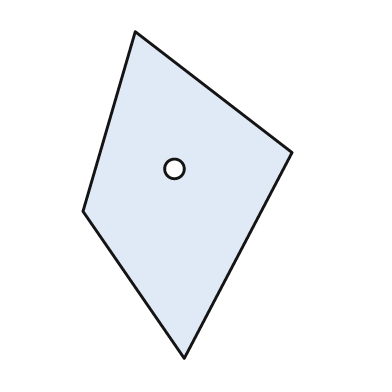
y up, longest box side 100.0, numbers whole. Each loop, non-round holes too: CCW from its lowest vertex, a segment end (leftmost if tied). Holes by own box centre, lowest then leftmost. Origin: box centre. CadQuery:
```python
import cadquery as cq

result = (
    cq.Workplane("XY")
    .moveTo(-1.0, -50.0)
    .lineTo(32.0, 13.0)
    .lineTo(-16.0, 50.0)
    .lineTo(-32.0, -5.0)
    .close()
    .moveTo(-4.0, 8.0)
    .circle(3.0)
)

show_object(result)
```